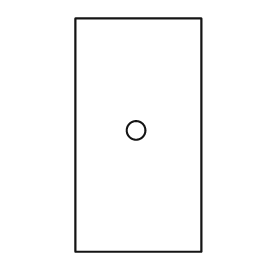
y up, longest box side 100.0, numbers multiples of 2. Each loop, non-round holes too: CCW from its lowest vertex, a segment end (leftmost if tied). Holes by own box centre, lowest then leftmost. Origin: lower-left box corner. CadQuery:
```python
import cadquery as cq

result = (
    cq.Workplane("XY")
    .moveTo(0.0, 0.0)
    .lineTo(54.0, 0.0)
    .lineTo(54.0, 100.0)
    .lineTo(0.0, 100.0)
    .close()
    .moveTo(26.0, 52.0)
    .circle(4.0)
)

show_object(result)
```